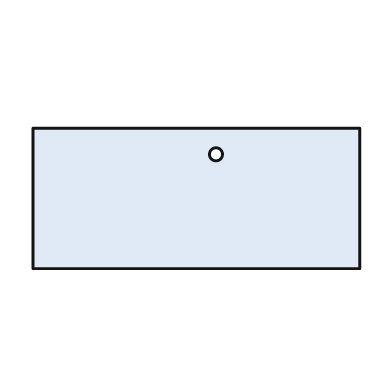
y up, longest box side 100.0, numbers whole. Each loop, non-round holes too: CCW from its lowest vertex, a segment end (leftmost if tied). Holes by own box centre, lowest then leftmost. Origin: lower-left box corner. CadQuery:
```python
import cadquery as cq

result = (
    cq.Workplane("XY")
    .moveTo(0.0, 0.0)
    .lineTo(100.0, 0.0)
    .lineTo(100.0, 43.0)
    .lineTo(0.0, 43.0)
    .close()
    .moveTo(56.0, 35.0)
    .circle(2.0)
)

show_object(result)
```